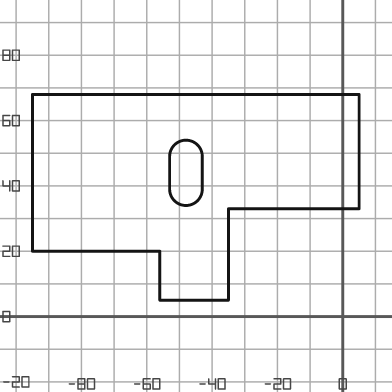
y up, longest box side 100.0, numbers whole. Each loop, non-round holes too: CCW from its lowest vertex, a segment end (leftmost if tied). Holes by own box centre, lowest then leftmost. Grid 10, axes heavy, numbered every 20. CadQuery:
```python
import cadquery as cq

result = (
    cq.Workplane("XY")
    .moveTo(-56.0, 5.0)
    .lineTo(-35.0, 5.0)
    .lineTo(-35.0, 33.0)
    .lineTo(5.0, 33.0)
    .lineTo(5.0, 68.0)
    .lineTo(-95.0, 68.0)
    .lineTo(-95.0, 20.0)
    .lineTo(-56.0, 20.0)
    .close()
    .moveTo(-53.0, 39.0)
    .threePointArc((-48.0, 34.0), (-43.0, 39.0))
    .lineTo(-43.0, 49.0)
    .threePointArc((-48.0, 54.0), (-53.0, 49.0))
    .close()
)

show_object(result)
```